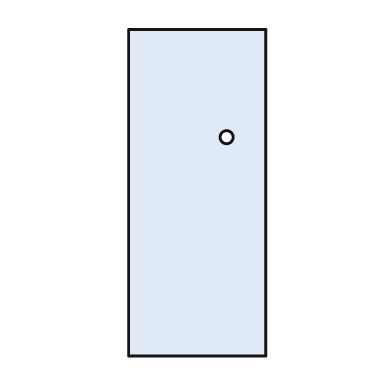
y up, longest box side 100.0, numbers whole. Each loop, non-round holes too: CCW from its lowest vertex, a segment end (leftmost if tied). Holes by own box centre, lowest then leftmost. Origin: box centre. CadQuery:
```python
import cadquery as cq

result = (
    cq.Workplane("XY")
    .moveTo(-21.0, -50.0)
    .lineTo(21.0, -50.0)
    .lineTo(21.0, 50.0)
    .lineTo(-21.0, 50.0)
    .close()
    .moveTo(9.0, 17.0)
    .circle(2.0)
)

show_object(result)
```